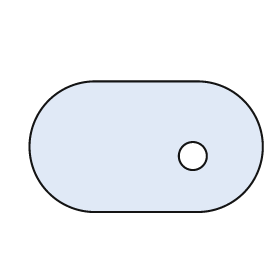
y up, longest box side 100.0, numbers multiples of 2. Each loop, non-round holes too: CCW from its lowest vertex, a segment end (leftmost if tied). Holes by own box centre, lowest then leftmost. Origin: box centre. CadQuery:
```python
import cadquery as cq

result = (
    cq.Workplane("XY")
    .moveTo(-22.0, -28.0)
    .lineTo(22.0, -28.0)
    .threePointArc((50.0, 0.0), (22.0, 28.0))
    .lineTo(-22.0, 28.0)
    .threePointArc((-50.0, 0.0), (-22.0, -28.0))
    .close()
    .moveTo(20.0, -4.0)
    .circle(6.0)
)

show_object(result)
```